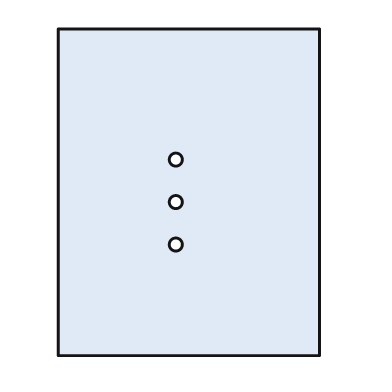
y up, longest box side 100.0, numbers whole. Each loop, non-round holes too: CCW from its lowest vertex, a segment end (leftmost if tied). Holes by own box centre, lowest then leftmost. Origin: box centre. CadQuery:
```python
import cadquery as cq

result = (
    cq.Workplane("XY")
    .moveTo(-40.0, -50.0)
    .lineTo(40.0, -50.0)
    .lineTo(40.0, 50.0)
    .lineTo(-40.0, 50.0)
    .close()
    .moveTo(-4.0, -16.0)
    .circle(2.0)
    .moveTo(-4.0, -3.0)
    .circle(2.0)
    .moveTo(-4.0, 10.0)
    .circle(2.0)
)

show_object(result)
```